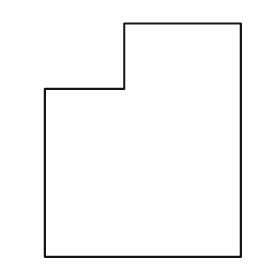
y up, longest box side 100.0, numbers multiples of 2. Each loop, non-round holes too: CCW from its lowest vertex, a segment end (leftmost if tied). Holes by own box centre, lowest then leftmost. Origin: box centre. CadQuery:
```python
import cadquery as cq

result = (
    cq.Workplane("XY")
    .moveTo(-42.0, -50.0)
    .lineTo(42.0, -50.0)
    .lineTo(42.0, 50.0)
    .lineTo(-8.0, 50.0)
    .lineTo(-8.0, 22.0)
    .lineTo(-42.0, 22.0)
    .close()
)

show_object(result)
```